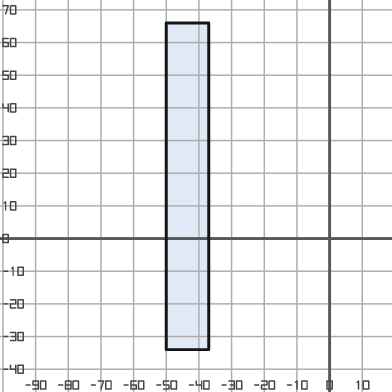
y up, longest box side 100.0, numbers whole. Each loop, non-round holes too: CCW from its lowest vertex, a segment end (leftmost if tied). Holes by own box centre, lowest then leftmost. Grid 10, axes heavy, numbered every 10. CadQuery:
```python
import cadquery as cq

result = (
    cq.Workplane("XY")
    .moveTo(-50.0, -34.0)
    .lineTo(-37.0, -34.0)
    .lineTo(-37.0, 66.0)
    .lineTo(-50.0, 66.0)
    .close()
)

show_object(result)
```